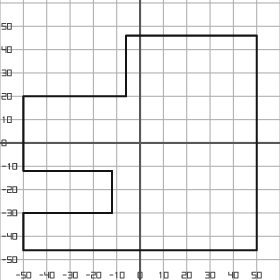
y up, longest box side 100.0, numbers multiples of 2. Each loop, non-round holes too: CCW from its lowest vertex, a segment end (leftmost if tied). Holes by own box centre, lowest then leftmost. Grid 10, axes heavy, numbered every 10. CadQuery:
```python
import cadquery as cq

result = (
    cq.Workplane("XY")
    .moveTo(-50.0, -46.0)
    .lineTo(50.0, -46.0)
    .lineTo(50.0, 46.0)
    .lineTo(-6.0, 46.0)
    .lineTo(-6.0, 20.0)
    .lineTo(-50.0, 20.0)
    .lineTo(-50.0, -12.0)
    .lineTo(-12.0, -12.0)
    .lineTo(-12.0, -30.0)
    .lineTo(-50.0, -30.0)
    .close()
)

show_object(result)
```